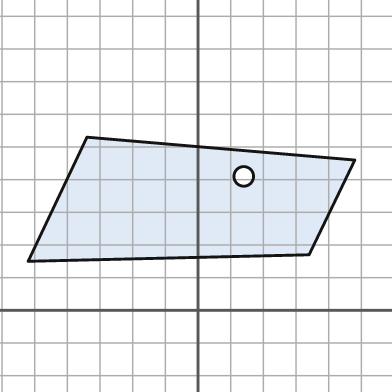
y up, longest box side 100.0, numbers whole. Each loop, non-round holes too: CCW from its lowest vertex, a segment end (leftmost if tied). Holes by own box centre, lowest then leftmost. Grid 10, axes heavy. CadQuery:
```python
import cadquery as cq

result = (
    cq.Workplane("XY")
    .moveTo(-52.0, 15.0)
    .lineTo(34.0, 17.0)
    .lineTo(48.0, 46.0)
    .lineTo(-34.0, 53.0)
    .close()
    .moveTo(14.0, 41.0)
    .circle(3.0)
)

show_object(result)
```